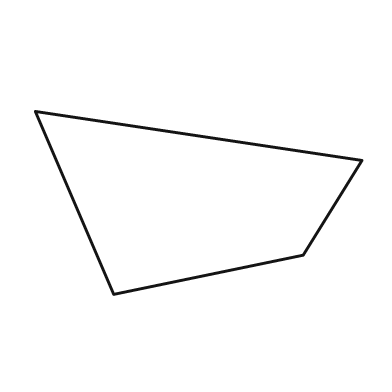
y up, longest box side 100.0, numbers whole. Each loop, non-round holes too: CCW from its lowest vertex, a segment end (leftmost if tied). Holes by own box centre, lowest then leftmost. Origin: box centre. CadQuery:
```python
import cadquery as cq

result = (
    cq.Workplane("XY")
    .moveTo(-26.0, -28.0)
    .lineTo(32.0, -16.0)
    .lineTo(50.0, 13.0)
    .lineTo(-50.0, 28.0)
    .close()
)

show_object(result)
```